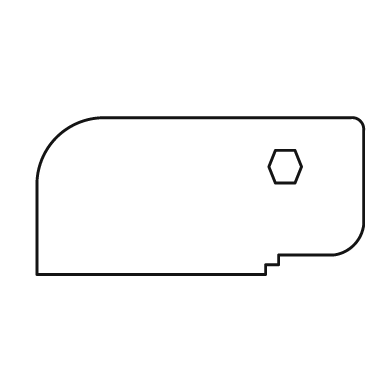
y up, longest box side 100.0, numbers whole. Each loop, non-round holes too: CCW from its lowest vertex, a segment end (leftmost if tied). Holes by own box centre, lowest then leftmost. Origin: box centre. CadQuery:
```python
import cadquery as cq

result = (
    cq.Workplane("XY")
    .moveTo(-50.0, -24.0)
    .lineTo(20.0, -24.0)
    .lineTo(20.0, -21.0)
    .lineTo(24.0, -21.0)
    .lineTo(24.0, -18.0)
    .lineTo(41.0, -18.0)
    .threePointArc((47.0, -15.0), (50.0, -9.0))
    .lineTo(50.0, 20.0)
    .threePointArc((49.0, 23.0), (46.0, 24.0))
    .lineTo(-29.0, 24.0)
    .threePointArc((-44.0, 18.0), (-50.0, 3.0))
    .close()
    .moveTo(23.0, 4.0)
    .lineTo(29.0, 4.0)
    .lineTo(31.0, 9.0)
    .lineTo(29.0, 14.0)
    .lineTo(23.0, 14.0)
    .lineTo(21.0, 9.0)
    .close()
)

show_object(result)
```